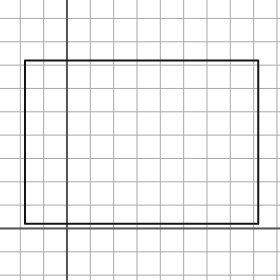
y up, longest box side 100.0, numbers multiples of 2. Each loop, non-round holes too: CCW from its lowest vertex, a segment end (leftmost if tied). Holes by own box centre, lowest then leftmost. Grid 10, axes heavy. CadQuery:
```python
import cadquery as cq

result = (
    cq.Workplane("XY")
    .moveTo(-18.0, 2.0)
    .lineTo(82.0, 2.0)
    .lineTo(82.0, 72.0)
    .lineTo(-18.0, 72.0)
    .close()
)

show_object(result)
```